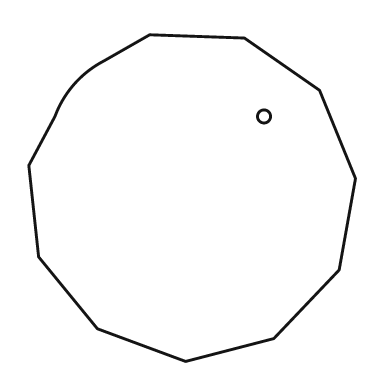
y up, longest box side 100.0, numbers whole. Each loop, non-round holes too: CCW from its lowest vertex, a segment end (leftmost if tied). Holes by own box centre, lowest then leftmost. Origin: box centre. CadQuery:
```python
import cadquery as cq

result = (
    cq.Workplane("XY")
    .moveTo(-2.0, -50.0)
    .lineTo(25.0, -43.0)
    .lineTo(45.0, -22.0)
    .lineTo(50.0, 6.0)
    .lineTo(39.0, 33.0)
    .lineTo(16.0, 49.0)
    .lineTo(-13.0, 50.0)
    .lineTo(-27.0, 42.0)
    .threePointArc((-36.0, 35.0), (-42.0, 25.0))
    .lineTo(-50.0, 10.0)
    .lineTo(-47.0, -18.0)
    .lineTo(-29.0, -40.0)
    .close()
    .moveTo(22.0, 25.0)
    .circle(2.0)
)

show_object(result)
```